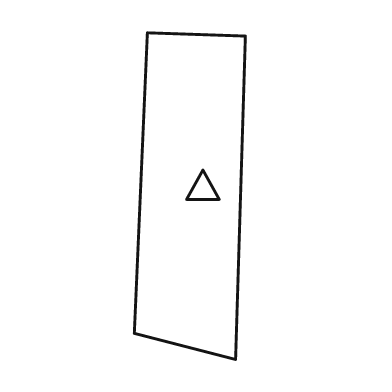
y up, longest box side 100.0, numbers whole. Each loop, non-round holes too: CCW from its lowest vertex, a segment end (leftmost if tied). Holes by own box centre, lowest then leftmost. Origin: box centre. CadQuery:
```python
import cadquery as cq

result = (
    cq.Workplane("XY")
    .moveTo(14.0, -50.0)
    .lineTo(17.0, 49.0)
    .lineTo(-13.0, 50.0)
    .lineTo(-17.0, -42.0)
    .close()
    .moveTo(-1.0, -1.0)
    .lineTo(9.0, -1.0)
    .lineTo(4.0, 8.0)
    .close()
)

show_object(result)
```